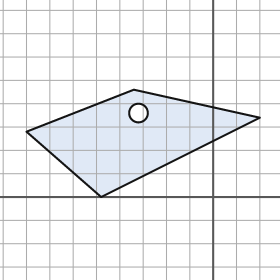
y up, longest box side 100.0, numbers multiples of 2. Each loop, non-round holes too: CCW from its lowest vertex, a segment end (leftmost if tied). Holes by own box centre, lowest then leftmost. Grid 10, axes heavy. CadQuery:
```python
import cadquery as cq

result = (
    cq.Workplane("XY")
    .moveTo(-48.0, 0.0)
    .lineTo(20.0, 34.0)
    .lineTo(-34.0, 46.0)
    .lineTo(-80.0, 28.0)
    .close()
    .moveTo(-32.0, 36.0)
    .circle(4.0)
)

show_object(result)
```